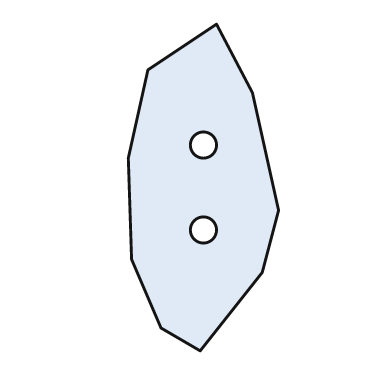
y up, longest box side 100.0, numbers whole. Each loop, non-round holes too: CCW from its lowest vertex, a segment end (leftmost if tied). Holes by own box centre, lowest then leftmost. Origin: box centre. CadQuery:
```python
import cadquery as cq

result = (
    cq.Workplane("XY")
    .moveTo(-1.0, -50.0)
    .lineTo(18.0, -26.0)
    .lineTo(23.0, -7.0)
    .lineTo(15.0, 29.0)
    .lineTo(4.0, 50.0)
    .lineTo(-17.0, 36.0)
    .lineTo(-23.0, 9.0)
    .lineTo(-22.0, -22.0)
    .lineTo(-13.0, -43.0)
    .close()
    .moveTo(0.0, -13.0)
    .circle(4.0)
    .moveTo(0.0, 13.0)
    .circle(4.0)
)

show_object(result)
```